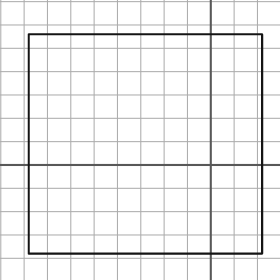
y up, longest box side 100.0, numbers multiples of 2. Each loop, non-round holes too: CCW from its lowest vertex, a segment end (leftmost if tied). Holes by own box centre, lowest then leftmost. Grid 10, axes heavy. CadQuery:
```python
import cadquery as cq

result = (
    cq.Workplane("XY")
    .moveTo(-78.0, -38.0)
    .lineTo(22.0, -38.0)
    .lineTo(22.0, 56.0)
    .lineTo(-78.0, 56.0)
    .close()
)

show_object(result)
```